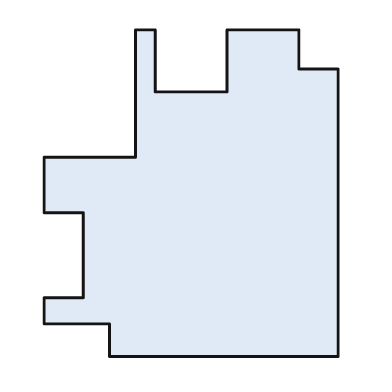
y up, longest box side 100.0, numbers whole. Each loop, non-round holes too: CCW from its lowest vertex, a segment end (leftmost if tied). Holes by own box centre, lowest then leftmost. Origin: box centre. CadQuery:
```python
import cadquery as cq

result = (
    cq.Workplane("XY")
    .moveTo(-25.0, -50.0)
    .lineTo(45.0, -50.0)
    .lineTo(45.0, 38.0)
    .lineTo(33.0, 38.0)
    .lineTo(33.0, 50.0)
    .lineTo(11.0, 50.0)
    .lineTo(11.0, 31.0)
    .lineTo(-11.0, 31.0)
    .lineTo(-11.0, 50.0)
    .lineTo(-17.0, 50.0)
    .lineTo(-17.0, 11.0)
    .lineTo(-45.0, 11.0)
    .lineTo(-45.0, -6.0)
    .lineTo(-33.0, -6.0)
    .lineTo(-33.0, -32.0)
    .lineTo(-45.0, -32.0)
    .lineTo(-45.0, -40.0)
    .lineTo(-25.0, -40.0)
    .close()
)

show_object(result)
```